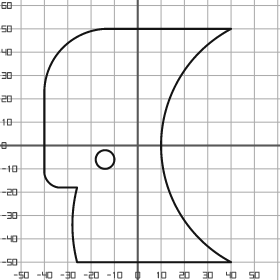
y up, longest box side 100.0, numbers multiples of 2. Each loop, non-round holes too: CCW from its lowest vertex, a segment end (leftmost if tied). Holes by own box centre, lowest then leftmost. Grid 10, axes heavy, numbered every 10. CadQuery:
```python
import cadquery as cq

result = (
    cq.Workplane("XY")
    .moveTo(-26.0, -50.0)
    .lineTo(40.0, -50.0)
    .threePointArc((10.0, 0.0), (40.0, 50.0))
    .lineTo(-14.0, 50.0)
    .threePointArc((-32.0, 42.0), (-40.0, 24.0))
    .lineTo(-40.0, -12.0)
    .threePointArc((-38.0, -16.0), (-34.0, -18.0))
    .lineTo(-26.0, -18.0)
    .threePointArc((-28.0, -34.0), (-26.0, -50.0))
    .close()
    .moveTo(-14.0, -6.0)
    .circle(4.0)
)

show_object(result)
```